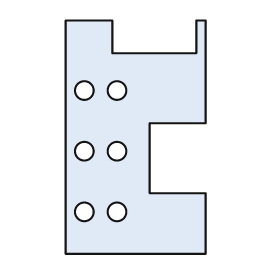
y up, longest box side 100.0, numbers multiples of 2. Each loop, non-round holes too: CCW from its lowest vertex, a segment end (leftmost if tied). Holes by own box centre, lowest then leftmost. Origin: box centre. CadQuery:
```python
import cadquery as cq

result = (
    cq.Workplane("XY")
    .moveTo(-30.0, -50.0)
    .lineTo(30.0, -50.0)
    .lineTo(30.0, -24.0)
    .lineTo(6.0, -24.0)
    .lineTo(6.0, 6.0)
    .lineTo(30.0, 6.0)
    .lineTo(30.0, 50.0)
    .lineTo(26.0, 50.0)
    .lineTo(26.0, 36.0)
    .lineTo(-10.0, 36.0)
    .lineTo(-10.0, 50.0)
    .lineTo(-30.0, 50.0)
    .close()
    .moveTo(-22.0, -32.0)
    .circle(4.0)
    .moveTo(-8.0, -32.0)
    .circle(4.0)
    .moveTo(-22.0, -6.0)
    .circle(4.0)
    .moveTo(-8.0, -6.0)
    .circle(4.0)
    .moveTo(-22.0, 20.0)
    .circle(4.0)
    .moveTo(-8.0, 20.0)
    .circle(4.0)
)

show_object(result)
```